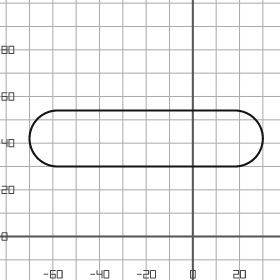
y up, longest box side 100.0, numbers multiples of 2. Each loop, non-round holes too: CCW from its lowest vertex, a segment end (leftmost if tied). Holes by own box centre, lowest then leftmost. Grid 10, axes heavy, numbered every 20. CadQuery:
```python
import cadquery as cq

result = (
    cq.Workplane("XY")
    .moveTo(-58.0, 30.0)
    .lineTo(18.0, 30.0)
    .threePointArc((30.0, 42.0), (18.0, 54.0))
    .lineTo(-58.0, 54.0)
    .threePointArc((-70.0, 42.0), (-58.0, 30.0))
    .close()
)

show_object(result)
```